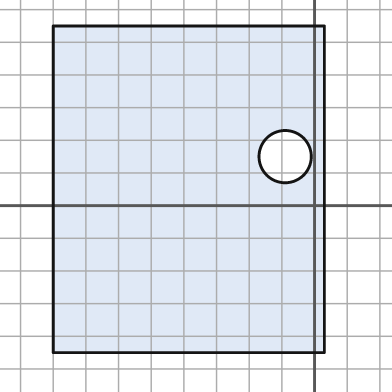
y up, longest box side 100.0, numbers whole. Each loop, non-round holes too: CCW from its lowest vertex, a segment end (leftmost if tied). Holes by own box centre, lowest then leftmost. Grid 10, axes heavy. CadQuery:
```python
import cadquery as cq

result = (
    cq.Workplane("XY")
    .moveTo(-80.0, -45.0)
    .lineTo(3.0, -45.0)
    .lineTo(3.0, 55.0)
    .lineTo(-80.0, 55.0)
    .close()
    .moveTo(-9.0, 15.0)
    .circle(8.0)
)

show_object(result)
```